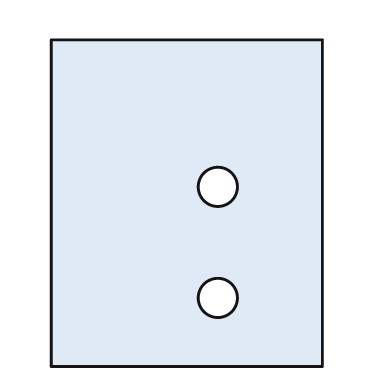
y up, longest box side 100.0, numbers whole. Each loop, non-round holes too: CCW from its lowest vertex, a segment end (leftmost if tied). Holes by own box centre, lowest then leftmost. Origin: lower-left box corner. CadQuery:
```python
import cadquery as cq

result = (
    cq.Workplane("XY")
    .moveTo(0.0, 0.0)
    .lineTo(83.0, 0.0)
    .lineTo(83.0, 100.0)
    .lineTo(0.0, 100.0)
    .close()
    .moveTo(51.0, 21.0)
    .circle(6.0)
    .moveTo(51.0, 55.0)
    .circle(6.0)
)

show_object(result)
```